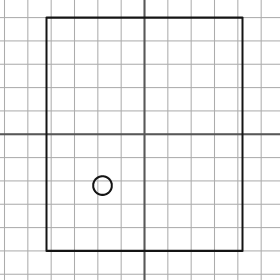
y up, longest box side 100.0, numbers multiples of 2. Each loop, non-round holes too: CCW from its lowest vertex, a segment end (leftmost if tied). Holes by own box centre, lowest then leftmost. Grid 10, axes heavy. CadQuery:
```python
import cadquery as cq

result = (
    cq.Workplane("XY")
    .moveTo(-42.0, -50.0)
    .lineTo(42.0, -50.0)
    .lineTo(42.0, 50.0)
    .lineTo(-42.0, 50.0)
    .close()
    .moveTo(-18.0, -22.0)
    .circle(4.0)
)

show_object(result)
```